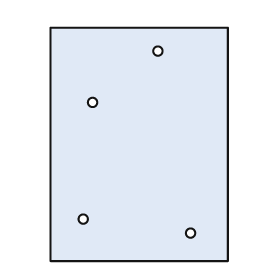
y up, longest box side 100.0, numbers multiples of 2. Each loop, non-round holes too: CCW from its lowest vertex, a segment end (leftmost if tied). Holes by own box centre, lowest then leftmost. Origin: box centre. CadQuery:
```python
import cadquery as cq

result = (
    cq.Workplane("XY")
    .moveTo(-38.0, -50.0)
    .lineTo(38.0, -50.0)
    .lineTo(38.0, 50.0)
    .lineTo(-38.0, 50.0)
    .close()
    .moveTo(22.0, -38.0)
    .circle(2.0)
    .moveTo(-24.0, -32.0)
    .circle(2.0)
    .moveTo(-20.0, 18.0)
    .circle(2.0)
    .moveTo(8.0, 40.0)
    .circle(2.0)
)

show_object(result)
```